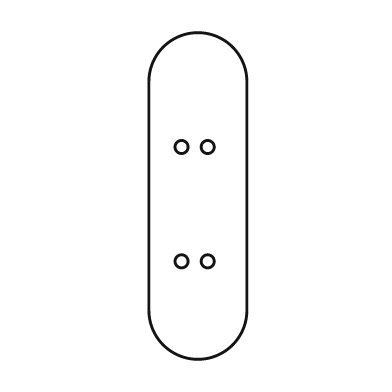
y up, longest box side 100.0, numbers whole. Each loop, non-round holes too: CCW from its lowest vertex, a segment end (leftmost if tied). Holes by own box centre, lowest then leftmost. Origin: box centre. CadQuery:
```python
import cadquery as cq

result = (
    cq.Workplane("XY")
    .moveTo(-15.0, -35.0)
    .threePointArc((0.0, -50.0), (15.0, -35.0))
    .lineTo(15.0, 35.0)
    .threePointArc((0.0, 50.0), (-15.0, 35.0))
    .close()
    .moveTo(-5.0, -20.0)
    .circle(2.0)
    .moveTo(3.0, -20.0)
    .circle(2.0)
    .moveTo(-5.0, 15.0)
    .circle(2.0)
    .moveTo(3.0, 15.0)
    .circle(2.0)
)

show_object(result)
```